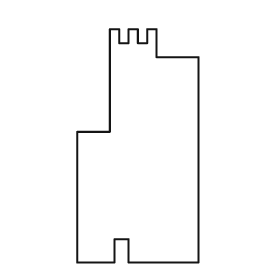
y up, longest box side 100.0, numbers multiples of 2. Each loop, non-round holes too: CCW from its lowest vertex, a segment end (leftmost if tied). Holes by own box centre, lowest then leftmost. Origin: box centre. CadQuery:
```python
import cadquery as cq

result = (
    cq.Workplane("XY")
    .moveTo(-26.0, -50.0)
    .lineTo(-10.0, -50.0)
    .lineTo(-10.0, -40.0)
    .lineTo(-4.0, -40.0)
    .lineTo(-4.0, -50.0)
    .lineTo(26.0, -50.0)
    .lineTo(26.0, 38.0)
    .lineTo(8.0, 38.0)
    .lineTo(8.0, 50.0)
    .lineTo(4.0, 50.0)
    .lineTo(4.0, 44.0)
    .lineTo(0.0, 44.0)
    .lineTo(0.0, 50.0)
    .lineTo(-4.0, 50.0)
    .lineTo(-4.0, 44.0)
    .lineTo(-8.0, 44.0)
    .lineTo(-8.0, 50.0)
    .lineTo(-12.0, 50.0)
    .lineTo(-12.0, 6.0)
    .lineTo(-26.0, 6.0)
    .close()
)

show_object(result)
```